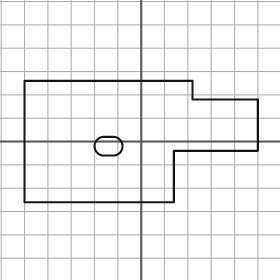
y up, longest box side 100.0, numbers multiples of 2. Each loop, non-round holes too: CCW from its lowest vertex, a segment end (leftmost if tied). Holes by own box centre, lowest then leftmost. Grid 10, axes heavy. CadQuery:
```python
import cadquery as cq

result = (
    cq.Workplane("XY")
    .moveTo(-50.0, -26.0)
    .lineTo(14.0, -26.0)
    .lineTo(14.0, -4.0)
    .lineTo(50.0, -4.0)
    .lineTo(50.0, 18.0)
    .lineTo(22.0, 18.0)
    .lineTo(22.0, 26.0)
    .lineTo(-50.0, 26.0)
    .close()
    .moveTo(-16.0, -6.0)
    .lineTo(-12.0, -6.0)
    .threePointArc((-8.0, -2.0), (-12.0, 2.0))
    .lineTo(-16.0, 2.0)
    .threePointArc((-20.0, -2.0), (-16.0, -6.0))
    .close()
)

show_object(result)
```